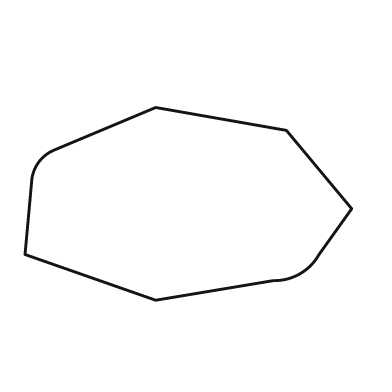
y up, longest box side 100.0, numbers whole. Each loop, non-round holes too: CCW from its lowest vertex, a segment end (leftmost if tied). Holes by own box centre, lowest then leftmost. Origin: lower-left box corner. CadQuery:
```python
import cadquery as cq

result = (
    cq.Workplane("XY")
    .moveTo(40.0, 0.0)
    .lineTo(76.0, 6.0)
    .threePointArc((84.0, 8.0), (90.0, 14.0))
    .lineTo(100.0, 28.0)
    .lineTo(80.0, 52.0)
    .lineTo(40.0, 59.0)
    .lineTo(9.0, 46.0)
    .threePointArc((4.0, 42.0), (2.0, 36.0))
    .lineTo(0.0, 14.0)
    .close()
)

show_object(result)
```